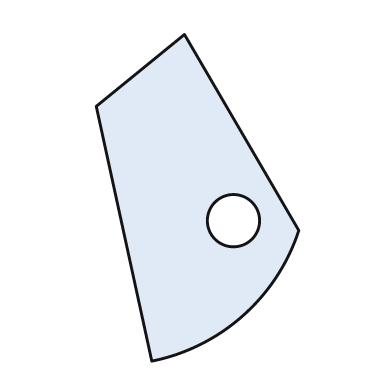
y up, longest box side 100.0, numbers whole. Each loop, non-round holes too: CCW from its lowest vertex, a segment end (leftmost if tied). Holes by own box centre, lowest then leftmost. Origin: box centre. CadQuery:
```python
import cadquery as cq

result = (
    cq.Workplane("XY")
    .moveTo(-14.0, -50.0)
    .threePointArc((14.0, -36.0), (31.0, -10.0))
    .lineTo(-4.0, 50.0)
    .lineTo(-31.0, 28.0)
    .close()
    .moveTo(11.0, -7.0)
    .circle(8.0)
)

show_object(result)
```